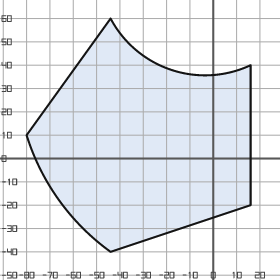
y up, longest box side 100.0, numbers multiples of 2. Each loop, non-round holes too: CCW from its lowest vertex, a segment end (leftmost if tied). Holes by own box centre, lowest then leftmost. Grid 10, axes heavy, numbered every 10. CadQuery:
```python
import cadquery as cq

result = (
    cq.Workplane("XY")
    .moveTo(-44.0, -40.0)
    .lineTo(16.0, -20.0)
    .lineTo(16.0, 40.0)
    .threePointArc((-18.0, 38.0), (-44.0, 60.0))
    .lineTo(-80.0, 10.0)
    .threePointArc((-66.0, -18.0), (-44.0, -40.0))
    .close()
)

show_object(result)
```